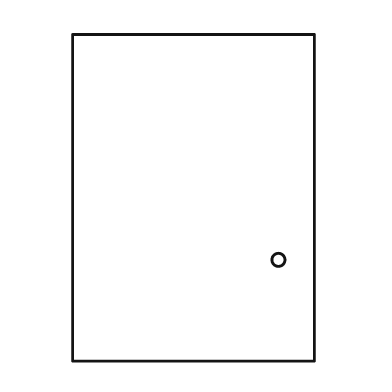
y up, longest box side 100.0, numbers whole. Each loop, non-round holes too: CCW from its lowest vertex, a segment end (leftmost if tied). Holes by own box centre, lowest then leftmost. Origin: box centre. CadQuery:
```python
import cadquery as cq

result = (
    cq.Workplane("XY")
    .moveTo(-37.0, -50.0)
    .lineTo(37.0, -50.0)
    .lineTo(37.0, 50.0)
    .lineTo(-37.0, 50.0)
    .close()
    .moveTo(26.0, -19.0)
    .circle(2.0)
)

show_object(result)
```